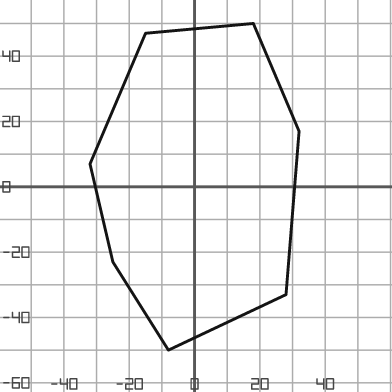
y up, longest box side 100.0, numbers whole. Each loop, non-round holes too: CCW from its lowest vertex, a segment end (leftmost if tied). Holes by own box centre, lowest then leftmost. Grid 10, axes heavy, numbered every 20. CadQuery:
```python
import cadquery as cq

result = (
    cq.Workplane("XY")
    .moveTo(-8.0, -50.0)
    .lineTo(28.0, -33.0)
    .lineTo(32.0, 17.0)
    .lineTo(18.0, 50.0)
    .lineTo(-15.0, 47.0)
    .lineTo(-32.0, 7.0)
    .lineTo(-25.0, -23.0)
    .close()
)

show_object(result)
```